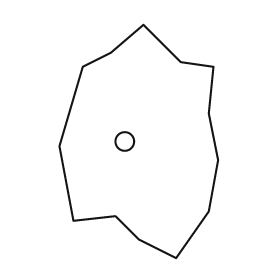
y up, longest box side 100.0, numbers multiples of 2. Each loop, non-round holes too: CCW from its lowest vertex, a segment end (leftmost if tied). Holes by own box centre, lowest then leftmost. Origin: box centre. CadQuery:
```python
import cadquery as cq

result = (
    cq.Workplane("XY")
    .moveTo(16.0, -50.0)
    .lineTo(30.0, -30.0)
    .lineTo(34.0, -8.0)
    .lineTo(30.0, 12.0)
    .lineTo(32.0, 32.0)
    .lineTo(18.0, 34.0)
    .lineTo(2.0, 50.0)
    .lineTo(-12.0, 38.0)
    .lineTo(-24.0, 32.0)
    .lineTo(-34.0, -2.0)
    .lineTo(-28.0, -34.0)
    .lineTo(-10.0, -32.0)
    .lineTo(0.0, -42.0)
    .close()
    .moveTo(-6.0, 0.0)
    .circle(4.0)
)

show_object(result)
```